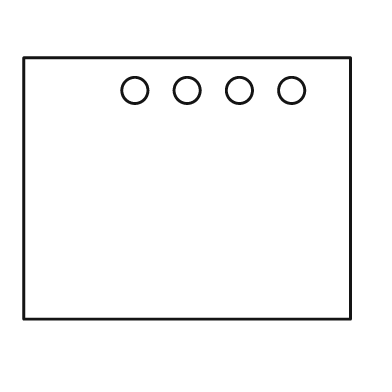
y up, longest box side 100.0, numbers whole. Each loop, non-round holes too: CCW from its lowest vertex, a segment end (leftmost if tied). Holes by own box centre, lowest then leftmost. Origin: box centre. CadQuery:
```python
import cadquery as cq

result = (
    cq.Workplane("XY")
    .moveTo(-50.0, -40.0)
    .lineTo(50.0, -40.0)
    .lineTo(50.0, 40.0)
    .lineTo(-50.0, 40.0)
    .close()
    .moveTo(-16.0, 30.0)
    .circle(4.0)
    .moveTo(0.0, 30.0)
    .circle(4.0)
    .moveTo(16.0, 30.0)
    .circle(4.0)
    .moveTo(32.0, 30.0)
    .circle(4.0)
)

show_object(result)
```